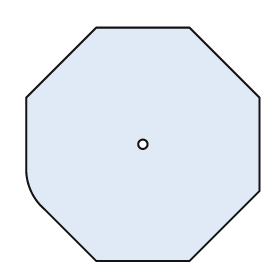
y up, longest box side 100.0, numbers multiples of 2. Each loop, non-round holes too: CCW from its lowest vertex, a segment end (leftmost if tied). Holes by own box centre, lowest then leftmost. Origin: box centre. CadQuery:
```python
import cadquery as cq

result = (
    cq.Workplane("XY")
    .moveTo(-20.0, -50.0)
    .lineTo(20.0, -50.0)
    .lineTo(50.0, -20.0)
    .lineTo(50.0, 20.0)
    .lineTo(20.0, 50.0)
    .lineTo(-20.0, 50.0)
    .lineTo(-50.0, 20.0)
    .lineTo(-50.0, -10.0)
    .threePointArc((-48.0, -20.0), (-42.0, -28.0))
    .close()
    .moveTo(0.0, 0.0)
    .circle(2.0)
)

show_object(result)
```